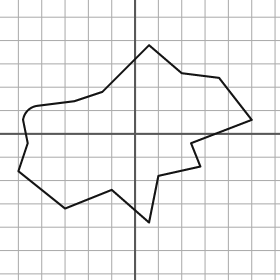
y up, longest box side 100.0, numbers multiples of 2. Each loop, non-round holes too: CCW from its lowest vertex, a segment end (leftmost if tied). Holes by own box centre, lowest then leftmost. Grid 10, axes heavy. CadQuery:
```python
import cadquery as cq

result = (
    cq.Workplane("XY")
    .moveTo(6.0, -38.0)
    .lineTo(10.0, -18.0)
    .lineTo(28.0, -14.0)
    .lineTo(24.0, -4.0)
    .lineTo(50.0, 6.0)
    .lineTo(36.0, 24.0)
    .lineTo(20.0, 26.0)
    .lineTo(6.0, 38.0)
    .lineTo(-14.0, 18.0)
    .lineTo(-26.0, 14.0)
    .lineTo(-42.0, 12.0)
    .threePointArc((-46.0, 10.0), (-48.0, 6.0))
    .lineTo(-46.0, -4.0)
    .lineTo(-50.0, -16.0)
    .lineTo(-30.0, -32.0)
    .lineTo(-10.0, -24.0)
    .close()
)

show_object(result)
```